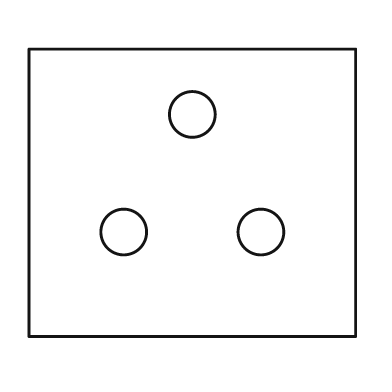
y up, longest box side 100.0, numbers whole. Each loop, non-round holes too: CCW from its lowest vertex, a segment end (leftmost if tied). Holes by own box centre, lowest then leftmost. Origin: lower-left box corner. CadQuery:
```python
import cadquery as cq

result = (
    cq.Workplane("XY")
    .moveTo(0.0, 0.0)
    .lineTo(100.0, 0.0)
    .lineTo(100.0, 88.0)
    .lineTo(0.0, 88.0)
    .close()
    .moveTo(29.0, 32.0)
    .circle(7.0)
    .moveTo(71.0, 32.0)
    .circle(7.0)
    .moveTo(50.0, 68.0)
    .circle(7.0)
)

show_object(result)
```